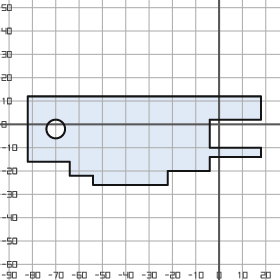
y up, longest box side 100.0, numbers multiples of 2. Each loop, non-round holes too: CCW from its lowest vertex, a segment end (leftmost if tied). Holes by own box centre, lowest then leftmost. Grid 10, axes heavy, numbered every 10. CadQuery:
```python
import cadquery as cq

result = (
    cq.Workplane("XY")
    .moveTo(-54.0, -26.0)
    .lineTo(-22.0, -26.0)
    .lineTo(-22.0, -20.0)
    .lineTo(-4.0, -20.0)
    .lineTo(-4.0, -14.0)
    .lineTo(18.0, -14.0)
    .lineTo(18.0, -10.0)
    .lineTo(-4.0, -10.0)
    .lineTo(-4.0, 2.0)
    .lineTo(18.0, 2.0)
    .lineTo(18.0, 12.0)
    .lineTo(-82.0, 12.0)
    .lineTo(-82.0, -16.0)
    .lineTo(-64.0, -16.0)
    .lineTo(-64.0, -22.0)
    .lineTo(-54.0, -22.0)
    .close()
    .moveTo(-70.0, -2.0)
    .circle(4.0)
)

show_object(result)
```